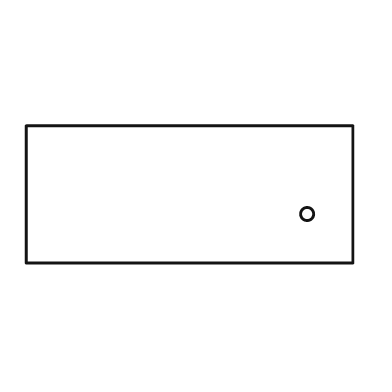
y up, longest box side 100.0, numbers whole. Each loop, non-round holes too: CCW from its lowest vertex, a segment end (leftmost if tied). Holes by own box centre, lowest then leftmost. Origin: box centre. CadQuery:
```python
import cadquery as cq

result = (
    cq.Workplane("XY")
    .moveTo(-50.0, -21.0)
    .lineTo(50.0, -21.0)
    .lineTo(50.0, 21.0)
    .lineTo(-50.0, 21.0)
    .close()
    .moveTo(36.0, -6.0)
    .circle(2.0)
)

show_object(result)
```